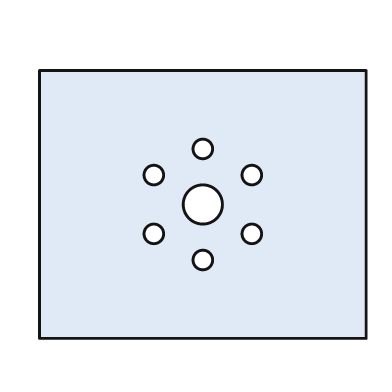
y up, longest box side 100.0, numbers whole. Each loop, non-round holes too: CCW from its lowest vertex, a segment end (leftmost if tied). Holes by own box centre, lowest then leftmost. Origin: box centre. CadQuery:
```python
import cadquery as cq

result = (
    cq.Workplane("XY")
    .moveTo(-50.0, -41.0)
    .lineTo(50.0, -41.0)
    .lineTo(50.0, 41.0)
    .lineTo(-50.0, 41.0)
    .close()
    .moveTo(0.0, -17.0)
    .circle(3.0)
    .moveTo(-15.0, -9.0)
    .circle(3.0)
    .moveTo(15.0, -9.0)
    .circle(3.0)
    .moveTo(0.0, 0.0)
    .circle(6.0)
    .moveTo(-15.0, 9.0)
    .circle(3.0)
    .moveTo(15.0, 9.0)
    .circle(3.0)
    .moveTo(0.0, 17.0)
    .circle(3.0)
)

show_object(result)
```